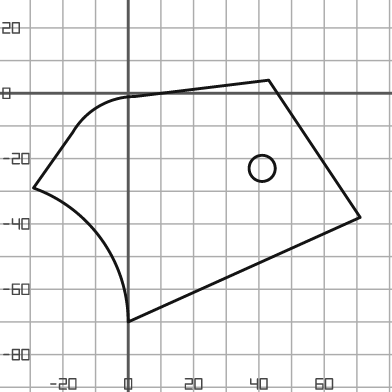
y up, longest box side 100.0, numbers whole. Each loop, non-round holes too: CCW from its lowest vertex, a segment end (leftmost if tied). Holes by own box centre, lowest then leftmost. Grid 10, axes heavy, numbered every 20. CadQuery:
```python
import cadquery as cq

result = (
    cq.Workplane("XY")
    .moveTo(0.0, -70.0)
    .lineTo(71.0, -38.0)
    .lineTo(43.0, 4.0)
    .lineTo(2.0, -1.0)
    .threePointArc((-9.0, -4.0), (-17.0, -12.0))
    .lineTo(-29.0, -29.0)
    .threePointArc((-8.0, -45.0), (0.0, -70.0))
    .close()
    .moveTo(41.0, -23.0)
    .circle(4.0)
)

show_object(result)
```